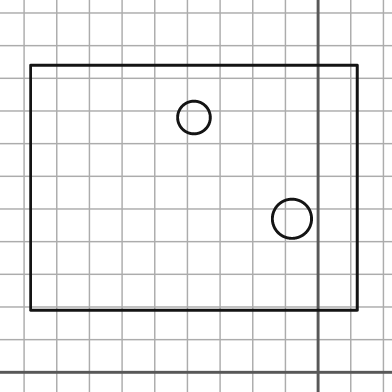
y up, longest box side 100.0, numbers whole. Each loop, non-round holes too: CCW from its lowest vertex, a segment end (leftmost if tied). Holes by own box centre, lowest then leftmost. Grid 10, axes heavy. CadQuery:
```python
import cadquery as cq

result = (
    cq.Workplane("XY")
    .moveTo(-88.0, 19.0)
    .lineTo(12.0, 19.0)
    .lineTo(12.0, 94.0)
    .lineTo(-88.0, 94.0)
    .close()
    .moveTo(-8.0, 47.0)
    .circle(6.0)
    .moveTo(-38.0, 78.0)
    .circle(5.0)
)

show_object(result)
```